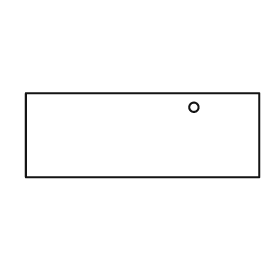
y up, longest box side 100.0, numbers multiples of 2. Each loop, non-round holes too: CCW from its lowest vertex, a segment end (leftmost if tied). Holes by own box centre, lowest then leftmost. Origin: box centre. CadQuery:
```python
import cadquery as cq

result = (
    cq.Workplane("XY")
    .moveTo(-50.0, -18.0)
    .lineTo(50.0, -18.0)
    .lineTo(50.0, 18.0)
    .lineTo(-50.0, 18.0)
    .close()
    .moveTo(22.0, 12.0)
    .circle(2.0)
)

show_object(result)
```